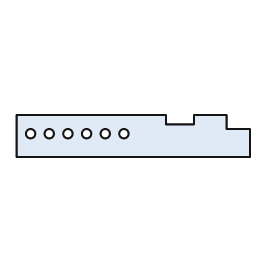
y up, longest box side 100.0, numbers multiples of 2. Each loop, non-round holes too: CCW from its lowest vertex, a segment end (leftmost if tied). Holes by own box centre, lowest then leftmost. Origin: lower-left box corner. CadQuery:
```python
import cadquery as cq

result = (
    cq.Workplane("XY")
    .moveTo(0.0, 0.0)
    .lineTo(100.0, 0.0)
    .lineTo(100.0, 12.0)
    .lineTo(90.0, 12.0)
    .lineTo(90.0, 18.0)
    .lineTo(76.0, 18.0)
    .lineTo(76.0, 14.0)
    .lineTo(64.0, 14.0)
    .lineTo(64.0, 18.0)
    .lineTo(0.0, 18.0)
    .close()
    .moveTo(6.0, 10.0)
    .circle(2.0)
    .moveTo(14.0, 10.0)
    .circle(2.0)
    .moveTo(22.0, 10.0)
    .circle(2.0)
    .moveTo(30.0, 10.0)
    .circle(2.0)
    .moveTo(38.0, 10.0)
    .circle(2.0)
    .moveTo(46.0, 10.0)
    .circle(2.0)
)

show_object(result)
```